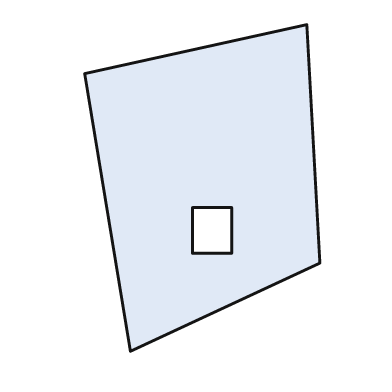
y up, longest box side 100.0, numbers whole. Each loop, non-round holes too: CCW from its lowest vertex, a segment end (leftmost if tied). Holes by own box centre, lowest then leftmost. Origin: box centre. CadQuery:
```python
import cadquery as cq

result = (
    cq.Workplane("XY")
    .moveTo(-22.0, -50.0)
    .lineTo(36.0, -23.0)
    .lineTo(32.0, 50.0)
    .lineTo(-36.0, 35.0)
    .close()
    .moveTo(-3.0, -20.0)
    .lineTo(9.0, -20.0)
    .lineTo(9.0, -6.0)
    .lineTo(-3.0, -6.0)
    .close()
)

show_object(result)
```